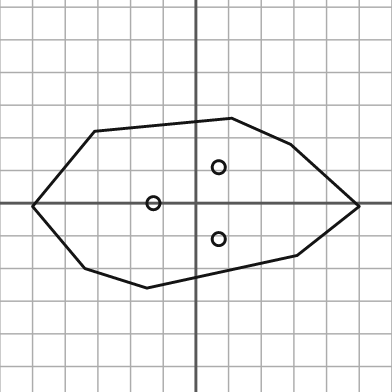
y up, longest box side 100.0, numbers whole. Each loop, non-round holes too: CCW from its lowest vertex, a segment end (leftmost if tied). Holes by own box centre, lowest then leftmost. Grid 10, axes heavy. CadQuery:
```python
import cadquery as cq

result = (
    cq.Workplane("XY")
    .moveTo(-15.0, -26.0)
    .lineTo(31.0, -16.0)
    .lineTo(50.0, -1.0)
    .lineTo(29.0, 18.0)
    .lineTo(11.0, 26.0)
    .lineTo(-31.0, 22.0)
    .lineTo(-50.0, -1.0)
    .lineTo(-34.0, -20.0)
    .close()
    .moveTo(7.0, -11.0)
    .circle(2.0)
    .moveTo(-13.0, 0.0)
    .circle(2.0)
    .moveTo(7.0, 11.0)
    .circle(2.0)
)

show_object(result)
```